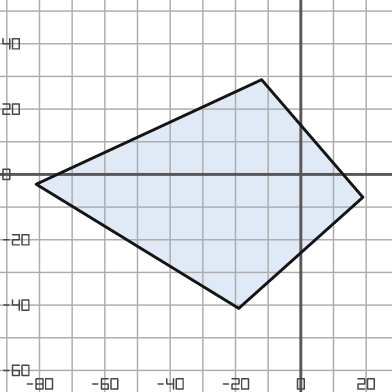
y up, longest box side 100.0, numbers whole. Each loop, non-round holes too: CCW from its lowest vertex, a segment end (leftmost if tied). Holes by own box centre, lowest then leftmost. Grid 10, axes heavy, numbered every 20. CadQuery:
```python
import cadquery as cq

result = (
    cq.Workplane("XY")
    .moveTo(-19.0, -41.0)
    .lineTo(19.0, -7.0)
    .lineTo(-12.0, 29.0)
    .lineTo(-81.0, -3.0)
    .close()
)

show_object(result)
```